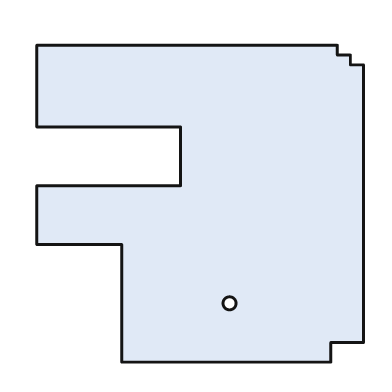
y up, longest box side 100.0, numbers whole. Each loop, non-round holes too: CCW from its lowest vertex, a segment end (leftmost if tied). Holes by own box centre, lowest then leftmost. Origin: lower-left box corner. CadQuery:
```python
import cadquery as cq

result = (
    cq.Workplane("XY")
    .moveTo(26.0, 0.0)
    .lineTo(90.0, 0.0)
    .lineTo(90.0, 6.0)
    .lineTo(100.0, 6.0)
    .lineTo(100.0, 91.0)
    .lineTo(96.0, 91.0)
    .lineTo(96.0, 94.0)
    .lineTo(92.0, 94.0)
    .lineTo(92.0, 97.0)
    .lineTo(0.0, 97.0)
    .lineTo(0.0, 72.0)
    .lineTo(44.0, 72.0)
    .lineTo(44.0, 54.0)
    .lineTo(0.0, 54.0)
    .lineTo(0.0, 36.0)
    .lineTo(26.0, 36.0)
    .close()
    .moveTo(59.0, 18.0)
    .circle(2.0)
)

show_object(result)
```